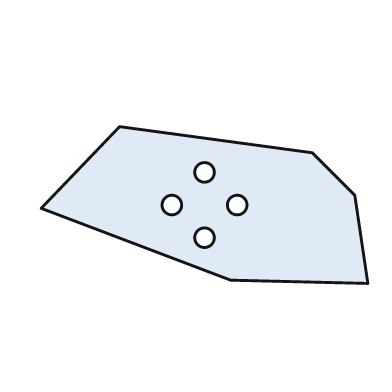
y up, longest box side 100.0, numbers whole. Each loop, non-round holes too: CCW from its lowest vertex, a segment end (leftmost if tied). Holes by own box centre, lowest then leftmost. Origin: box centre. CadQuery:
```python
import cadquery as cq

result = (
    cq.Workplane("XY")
    .moveTo(50.0, -24.0)
    .lineTo(46.0, 3.0)
    .lineTo(33.0, 16.0)
    .lineTo(-26.0, 24.0)
    .lineTo(-50.0, -1.0)
    .lineTo(8.0, -23.0)
    .close()
    .moveTo(0.0, -10.0)
    .circle(3.0)
    .moveTo(-10.0, 0.0)
    .circle(3.0)
    .moveTo(10.0, 0.0)
    .circle(3.0)
    .moveTo(0.0, 10.0)
    .circle(3.0)
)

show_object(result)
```